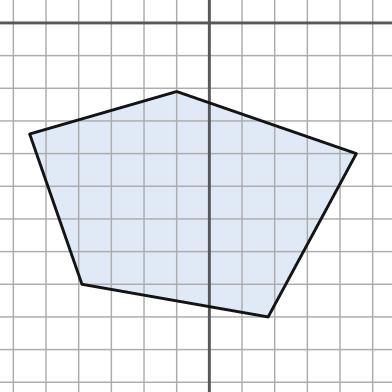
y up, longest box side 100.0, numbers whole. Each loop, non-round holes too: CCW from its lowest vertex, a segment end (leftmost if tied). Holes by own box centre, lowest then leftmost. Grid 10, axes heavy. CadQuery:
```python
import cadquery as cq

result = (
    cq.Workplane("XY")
    .moveTo(18.0, -90.0)
    .lineTo(45.0, -40.0)
    .lineTo(-10.0, -21.0)
    .lineTo(-55.0, -34.0)
    .lineTo(-39.0, -80.0)
    .close()
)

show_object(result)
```